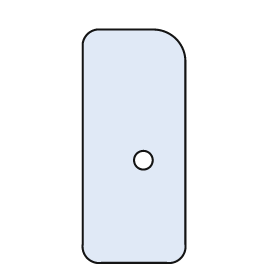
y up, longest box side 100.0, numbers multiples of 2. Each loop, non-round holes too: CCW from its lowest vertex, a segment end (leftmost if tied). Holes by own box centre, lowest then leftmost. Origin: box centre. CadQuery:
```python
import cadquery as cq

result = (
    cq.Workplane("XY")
    .moveTo(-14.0, -50.0)
    .lineTo(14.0, -50.0)
    .threePointArc((20.0, -48.0), (22.0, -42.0))
    .lineTo(22.0, 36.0)
    .threePointArc((18.0, 46.0), (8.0, 50.0))
    .lineTo(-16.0, 50.0)
    .threePointArc((-20.0, 48.0), (-22.0, 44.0))
    .lineTo(-22.0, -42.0)
    .threePointArc((-20.0, -48.0), (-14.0, -50.0))
    .close()
    .moveTo(4.0, -6.0)
    .circle(4.0)
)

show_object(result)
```